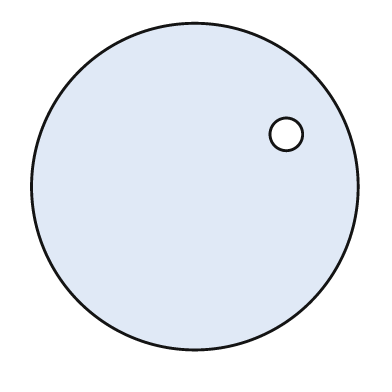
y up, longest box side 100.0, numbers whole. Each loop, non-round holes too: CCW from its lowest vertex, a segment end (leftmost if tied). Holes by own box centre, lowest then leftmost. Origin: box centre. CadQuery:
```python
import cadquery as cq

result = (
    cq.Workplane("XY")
    .moveTo(0.0, 0.0)
    .circle(50.0)
    .moveTo(28.0, 16.0)
    .circle(5.0)
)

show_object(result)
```